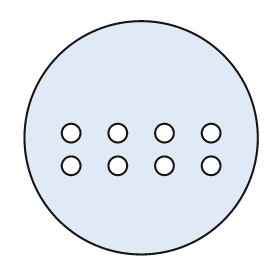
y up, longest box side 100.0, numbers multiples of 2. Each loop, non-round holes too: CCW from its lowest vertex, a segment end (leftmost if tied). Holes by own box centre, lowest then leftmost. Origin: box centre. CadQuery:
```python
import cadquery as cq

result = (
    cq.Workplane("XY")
    .moveTo(0.0, 0.0)
    .circle(50.0)
    .moveTo(-30.0, -12.0)
    .circle(4.0)
    .moveTo(-10.0, -12.0)
    .circle(4.0)
    .moveTo(10.0, -12.0)
    .circle(4.0)
    .moveTo(30.0, -12.0)
    .circle(4.0)
    .moveTo(-30.0, 2.0)
    .circle(4.0)
    .moveTo(-10.0, 2.0)
    .circle(4.0)
    .moveTo(10.0, 2.0)
    .circle(4.0)
    .moveTo(30.0, 2.0)
    .circle(4.0)
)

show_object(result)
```